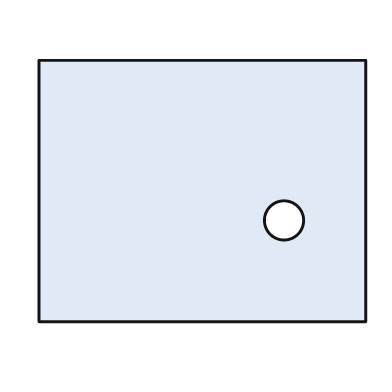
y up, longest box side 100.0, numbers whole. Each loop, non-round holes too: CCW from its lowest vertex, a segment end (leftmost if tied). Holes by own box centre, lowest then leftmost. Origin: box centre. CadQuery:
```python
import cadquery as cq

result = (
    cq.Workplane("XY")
    .moveTo(-50.0, -40.0)
    .lineTo(50.0, -40.0)
    .lineTo(50.0, 40.0)
    .lineTo(-50.0, 40.0)
    .close()
    .moveTo(25.0, -9.0)
    .circle(6.0)
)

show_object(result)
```